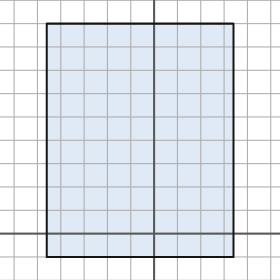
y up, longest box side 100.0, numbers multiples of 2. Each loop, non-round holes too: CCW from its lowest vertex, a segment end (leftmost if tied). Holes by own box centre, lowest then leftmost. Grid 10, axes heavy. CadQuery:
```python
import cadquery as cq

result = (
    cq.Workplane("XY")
    .moveTo(-46.0, -10.0)
    .lineTo(34.0, -10.0)
    .lineTo(34.0, 90.0)
    .lineTo(-46.0, 90.0)
    .close()
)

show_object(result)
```